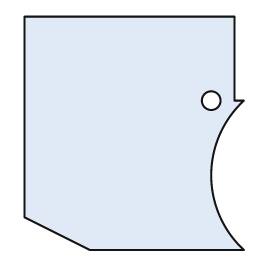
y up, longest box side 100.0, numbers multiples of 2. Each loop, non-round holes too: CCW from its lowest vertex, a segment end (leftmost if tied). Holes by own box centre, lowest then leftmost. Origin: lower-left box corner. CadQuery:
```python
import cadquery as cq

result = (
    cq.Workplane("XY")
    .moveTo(28.0, 0.0)
    .lineTo(94.0, 0.0)
    .threePointArc((80.0, 32.0), (94.0, 64.0))
    .lineTo(90.0, 64.0)
    .lineTo(90.0, 100.0)
    .lineTo(0.0, 100.0)
    .lineTo(0.0, 14.0)
    .close()
    .moveTo(80.0, 64.0)
    .circle(4.0)
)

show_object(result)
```